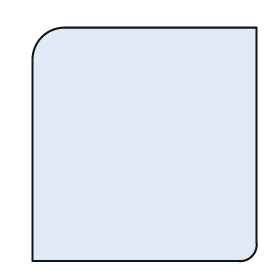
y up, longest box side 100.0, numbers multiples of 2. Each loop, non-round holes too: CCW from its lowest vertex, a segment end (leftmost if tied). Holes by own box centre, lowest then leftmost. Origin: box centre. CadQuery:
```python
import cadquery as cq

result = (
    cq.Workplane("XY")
    .moveTo(-48.0, -50.0)
    .lineTo(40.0, -50.0)
    .threePointArc((46.0, -48.0), (48.0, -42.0))
    .lineTo(48.0, 50.0)
    .lineTo(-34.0, 50.0)
    .threePointArc((-44.0, 46.0), (-48.0, 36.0))
    .close()
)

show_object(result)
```